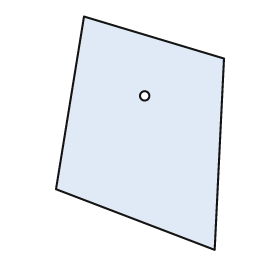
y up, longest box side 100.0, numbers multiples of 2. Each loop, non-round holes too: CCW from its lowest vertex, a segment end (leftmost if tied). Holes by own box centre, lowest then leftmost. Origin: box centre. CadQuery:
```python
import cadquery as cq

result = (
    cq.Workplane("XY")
    .moveTo(32.0, -50.0)
    .lineTo(36.0, 32.0)
    .lineTo(-24.0, 50.0)
    .lineTo(-36.0, -24.0)
    .close()
    .moveTo(2.0, 16.0)
    .circle(2.0)
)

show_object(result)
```